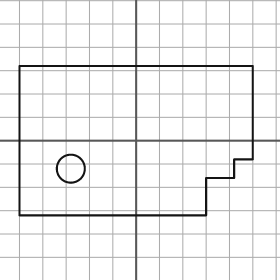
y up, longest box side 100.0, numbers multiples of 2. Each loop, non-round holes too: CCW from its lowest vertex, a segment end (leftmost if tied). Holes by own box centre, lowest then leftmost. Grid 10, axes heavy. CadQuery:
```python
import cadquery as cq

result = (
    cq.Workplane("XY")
    .moveTo(-50.0, -32.0)
    .lineTo(30.0, -32.0)
    .lineTo(30.0, -16.0)
    .lineTo(42.0, -16.0)
    .lineTo(42.0, -8.0)
    .lineTo(50.0, -8.0)
    .lineTo(50.0, 32.0)
    .lineTo(-50.0, 32.0)
    .close()
    .moveTo(-28.0, -12.0)
    .circle(6.0)
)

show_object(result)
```